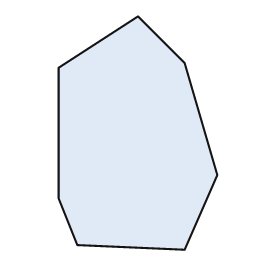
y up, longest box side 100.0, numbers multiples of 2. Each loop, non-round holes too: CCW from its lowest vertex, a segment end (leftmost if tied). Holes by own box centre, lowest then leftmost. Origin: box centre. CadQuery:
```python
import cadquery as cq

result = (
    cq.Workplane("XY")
    .moveTo(20.0, -50.0)
    .lineTo(34.0, -18.0)
    .lineTo(20.0, 30.0)
    .lineTo(0.0, 50.0)
    .lineTo(-34.0, 28.0)
    .lineTo(-34.0, -28.0)
    .lineTo(-26.0, -48.0)
    .close()
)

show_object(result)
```